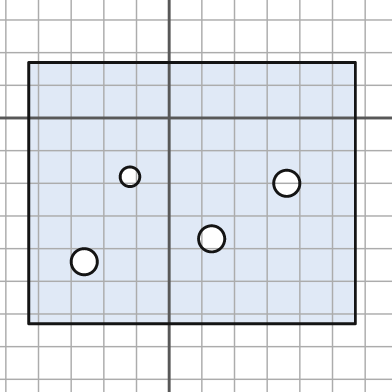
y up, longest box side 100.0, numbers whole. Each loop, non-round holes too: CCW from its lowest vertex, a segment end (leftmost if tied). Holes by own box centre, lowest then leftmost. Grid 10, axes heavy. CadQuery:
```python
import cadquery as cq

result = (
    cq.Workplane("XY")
    .moveTo(-43.0, -63.0)
    .lineTo(57.0, -63.0)
    .lineTo(57.0, 17.0)
    .lineTo(-43.0, 17.0)
    .close()
    .moveTo(-26.0, -44.0)
    .circle(4.0)
    .moveTo(13.0, -37.0)
    .circle(4.0)
    .moveTo(36.0, -20.0)
    .circle(4.0)
    .moveTo(-12.0, -18.0)
    .circle(3.0)
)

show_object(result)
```